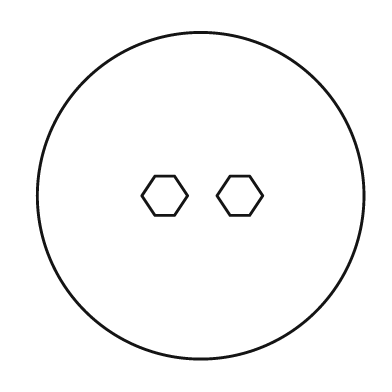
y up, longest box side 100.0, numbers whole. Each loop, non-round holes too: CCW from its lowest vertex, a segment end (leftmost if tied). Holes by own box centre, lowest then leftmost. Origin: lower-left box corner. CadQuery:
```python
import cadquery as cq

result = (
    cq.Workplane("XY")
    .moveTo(50.0, 50.0)
    .circle(50.0)
    .moveTo(36.0, 44.0)
    .lineTo(42.0, 44.0)
    .lineTo(46.0, 50.0)
    .lineTo(42.0, 56.0)
    .lineTo(36.0, 56.0)
    .lineTo(32.0, 50.0)
    .close()
    .moveTo(59.0, 44.0)
    .lineTo(65.0, 44.0)
    .lineTo(69.0, 50.0)
    .lineTo(65.0, 56.0)
    .lineTo(59.0, 56.0)
    .lineTo(55.0, 50.0)
    .close()
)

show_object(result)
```